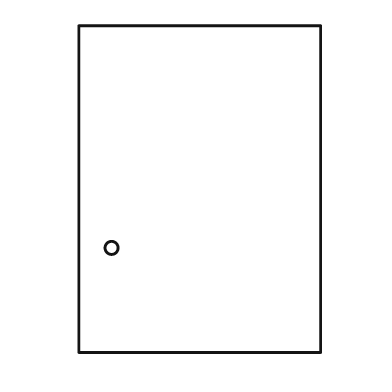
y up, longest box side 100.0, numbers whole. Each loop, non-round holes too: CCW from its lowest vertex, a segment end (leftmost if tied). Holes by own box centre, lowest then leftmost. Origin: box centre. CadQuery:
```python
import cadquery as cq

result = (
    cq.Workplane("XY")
    .moveTo(-37.0, -50.0)
    .lineTo(37.0, -50.0)
    .lineTo(37.0, 50.0)
    .lineTo(-37.0, 50.0)
    .close()
    .moveTo(-27.0, -18.0)
    .circle(2.0)
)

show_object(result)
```